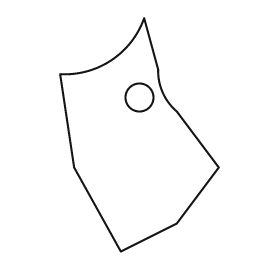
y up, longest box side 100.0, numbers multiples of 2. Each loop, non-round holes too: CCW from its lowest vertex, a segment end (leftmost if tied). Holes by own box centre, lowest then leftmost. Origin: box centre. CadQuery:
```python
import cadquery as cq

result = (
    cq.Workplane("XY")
    .moveTo(-8.0, -50.0)
    .lineTo(16.0, -38.0)
    .lineTo(34.0, -14.0)
    .lineTo(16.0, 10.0)
    .threePointArc((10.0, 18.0), (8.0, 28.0))
    .lineTo(2.0, 50.0)
    .threePointArc((-12.0, 32.0), (-34.0, 26.0))
    .lineTo(-28.0, -14.0)
    .close()
    .moveTo(0.0, 16.0)
    .circle(6.0)
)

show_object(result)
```